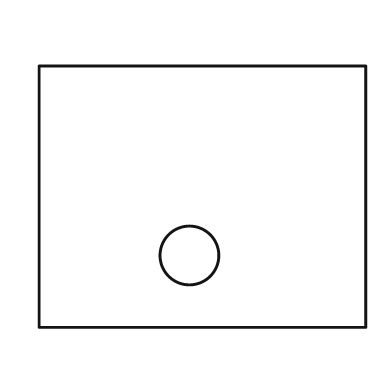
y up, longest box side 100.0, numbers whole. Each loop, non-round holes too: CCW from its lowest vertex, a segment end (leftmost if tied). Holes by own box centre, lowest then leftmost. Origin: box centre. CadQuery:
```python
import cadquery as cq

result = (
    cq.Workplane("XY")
    .moveTo(-50.0, -40.0)
    .lineTo(50.0, -40.0)
    .lineTo(50.0, 40.0)
    .lineTo(-50.0, 40.0)
    .close()
    .moveTo(-4.0, -18.0)
    .circle(9.0)
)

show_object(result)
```